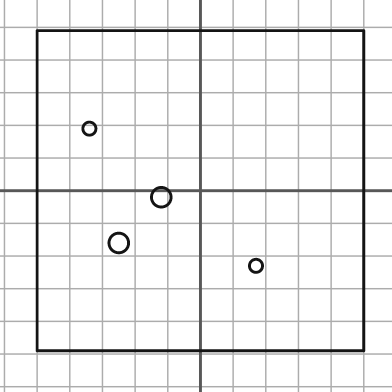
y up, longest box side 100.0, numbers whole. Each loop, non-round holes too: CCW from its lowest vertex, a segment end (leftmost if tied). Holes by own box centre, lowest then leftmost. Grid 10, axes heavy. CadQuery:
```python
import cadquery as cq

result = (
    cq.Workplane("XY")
    .moveTo(-50.0, -49.0)
    .lineTo(50.0, -49.0)
    .lineTo(50.0, 49.0)
    .lineTo(-50.0, 49.0)
    .close()
    .moveTo(17.0, -23.0)
    .circle(2.0)
    .moveTo(-25.0, -16.0)
    .circle(3.0)
    .moveTo(-12.0, -2.0)
    .circle(3.0)
    .moveTo(-34.0, 19.0)
    .circle(2.0)
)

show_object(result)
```